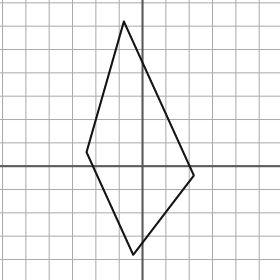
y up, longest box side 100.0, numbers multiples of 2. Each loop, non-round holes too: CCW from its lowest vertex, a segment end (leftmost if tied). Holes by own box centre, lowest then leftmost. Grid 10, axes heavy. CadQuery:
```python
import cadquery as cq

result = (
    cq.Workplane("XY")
    .moveTo(-4.0, -38.0)
    .lineTo(22.0, -4.0)
    .lineTo(-8.0, 62.0)
    .lineTo(-24.0, 6.0)
    .close()
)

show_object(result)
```